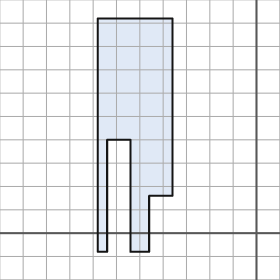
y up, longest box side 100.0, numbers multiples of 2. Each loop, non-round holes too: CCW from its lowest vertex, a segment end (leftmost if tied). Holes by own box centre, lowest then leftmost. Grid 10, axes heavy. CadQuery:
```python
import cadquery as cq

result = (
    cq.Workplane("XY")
    .moveTo(-68.0, -8.0)
    .lineTo(-64.0, -8.0)
    .lineTo(-64.0, 40.0)
    .lineTo(-54.0, 40.0)
    .lineTo(-54.0, -8.0)
    .lineTo(-46.0, -8.0)
    .lineTo(-46.0, 16.0)
    .lineTo(-36.0, 16.0)
    .lineTo(-36.0, 92.0)
    .lineTo(-68.0, 92.0)
    .close()
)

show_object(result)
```